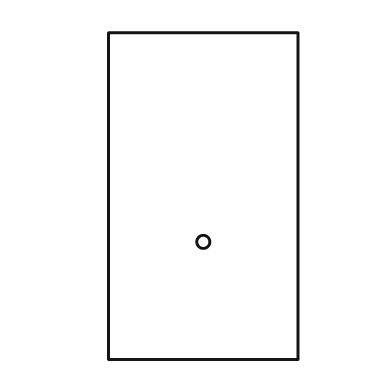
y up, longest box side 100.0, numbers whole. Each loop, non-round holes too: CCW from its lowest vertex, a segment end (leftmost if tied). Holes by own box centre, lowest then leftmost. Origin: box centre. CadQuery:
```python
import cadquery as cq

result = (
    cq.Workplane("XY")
    .moveTo(-29.0, -50.0)
    .lineTo(29.0, -50.0)
    .lineTo(29.0, 50.0)
    .lineTo(-29.0, 50.0)
    .close()
    .moveTo(0.0, -14.0)
    .circle(2.0)
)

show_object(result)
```